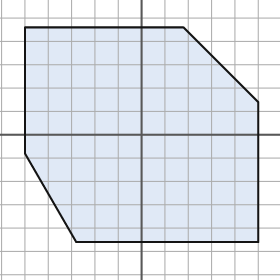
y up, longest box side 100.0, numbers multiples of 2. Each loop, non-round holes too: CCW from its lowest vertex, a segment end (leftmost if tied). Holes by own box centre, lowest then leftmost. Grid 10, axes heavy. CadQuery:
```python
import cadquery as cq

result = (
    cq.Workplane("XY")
    .moveTo(-28.0, -46.0)
    .lineTo(50.0, -46.0)
    .lineTo(50.0, 14.0)
    .lineTo(18.0, 46.0)
    .lineTo(-50.0, 46.0)
    .lineTo(-50.0, -8.0)
    .close()
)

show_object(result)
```